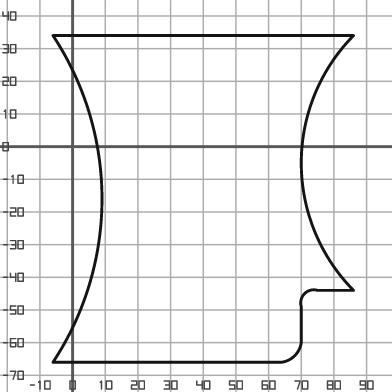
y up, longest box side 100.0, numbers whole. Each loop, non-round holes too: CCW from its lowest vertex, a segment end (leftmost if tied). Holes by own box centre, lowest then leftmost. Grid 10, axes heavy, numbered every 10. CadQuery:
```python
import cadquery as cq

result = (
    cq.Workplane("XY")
    .moveTo(-6.0, -66.0)
    .lineTo(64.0, -66.0)
    .threePointArc((68.0, -64.0), (70.0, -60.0))
    .lineTo(70.0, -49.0)
    .threePointArc((71.0, -45.0), (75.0, -44.0))
    .lineTo(86.0, -44.0)
    .threePointArc((70.0, -5.0), (86.0, 34.0))
    .lineTo(-6.0, 34.0)
    .threePointArc((9.0, -16.0), (-6.0, -66.0))
    .close()
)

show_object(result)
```